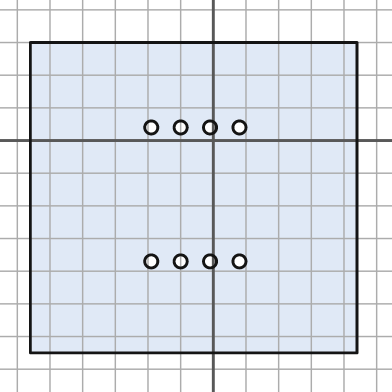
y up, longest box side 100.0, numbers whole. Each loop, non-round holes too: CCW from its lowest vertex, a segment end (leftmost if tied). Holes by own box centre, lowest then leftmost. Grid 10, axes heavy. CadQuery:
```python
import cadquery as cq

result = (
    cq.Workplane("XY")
    .moveTo(-56.0, -65.0)
    .lineTo(44.0, -65.0)
    .lineTo(44.0, 30.0)
    .lineTo(-56.0, 30.0)
    .close()
    .moveTo(-19.0, -37.0)
    .circle(2.0)
    .moveTo(-10.0, -37.0)
    .circle(2.0)
    .moveTo(-1.0, -37.0)
    .circle(2.0)
    .moveTo(8.0, -37.0)
    .circle(2.0)
    .moveTo(-19.0, 4.0)
    .circle(2.0)
    .moveTo(-10.0, 4.0)
    .circle(2.0)
    .moveTo(-1.0, 4.0)
    .circle(2.0)
    .moveTo(8.0, 4.0)
    .circle(2.0)
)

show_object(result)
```